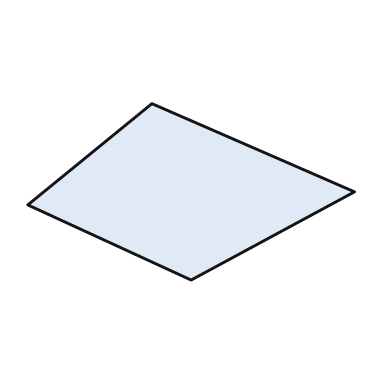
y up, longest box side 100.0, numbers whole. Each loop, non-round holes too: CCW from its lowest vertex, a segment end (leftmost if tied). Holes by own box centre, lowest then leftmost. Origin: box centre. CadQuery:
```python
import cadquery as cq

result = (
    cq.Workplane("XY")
    .moveTo(0.0, -27.0)
    .lineTo(50.0, 0.0)
    .lineTo(-12.0, 27.0)
    .lineTo(-50.0, -4.0)
    .close()
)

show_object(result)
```